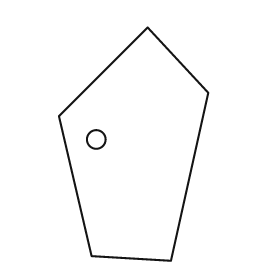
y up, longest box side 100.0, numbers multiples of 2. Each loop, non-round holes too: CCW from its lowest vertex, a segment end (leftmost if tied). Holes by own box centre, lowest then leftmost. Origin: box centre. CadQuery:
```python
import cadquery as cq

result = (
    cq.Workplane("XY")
    .moveTo(16.0, -50.0)
    .lineTo(32.0, 22.0)
    .lineTo(6.0, 50.0)
    .lineTo(-32.0, 12.0)
    .lineTo(-18.0, -48.0)
    .close()
    .moveTo(-16.0, 2.0)
    .circle(4.0)
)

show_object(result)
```